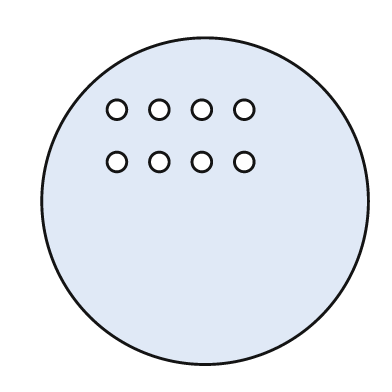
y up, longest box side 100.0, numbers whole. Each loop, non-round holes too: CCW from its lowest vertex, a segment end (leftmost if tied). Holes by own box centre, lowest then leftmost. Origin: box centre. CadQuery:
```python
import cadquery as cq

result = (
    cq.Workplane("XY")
    .moveTo(0.0, 0.0)
    .circle(50.0)
    .moveTo(-27.0, 12.0)
    .circle(3.0)
    .moveTo(-14.0, 12.0)
    .circle(3.0)
    .moveTo(-1.0, 12.0)
    .circle(3.0)
    .moveTo(12.0, 12.0)
    .circle(3.0)
    .moveTo(-27.0, 28.0)
    .circle(3.0)
    .moveTo(-14.0, 28.0)
    .circle(3.0)
    .moveTo(-1.0, 28.0)
    .circle(3.0)
    .moveTo(12.0, 28.0)
    .circle(3.0)
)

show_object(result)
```